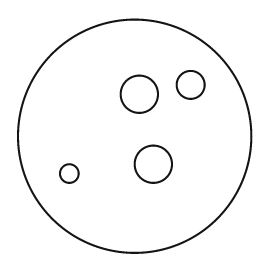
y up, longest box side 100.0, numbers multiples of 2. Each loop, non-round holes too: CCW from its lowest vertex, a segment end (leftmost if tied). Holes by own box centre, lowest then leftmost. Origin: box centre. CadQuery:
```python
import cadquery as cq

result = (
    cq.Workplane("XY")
    .moveTo(0.0, 0.0)
    .circle(50.0)
    .moveTo(-28.0, -16.0)
    .circle(4.0)
    .moveTo(8.0, -12.0)
    .circle(8.0)
    .moveTo(2.0, 18.0)
    .circle(8.0)
    .moveTo(24.0, 22.0)
    .circle(6.0)
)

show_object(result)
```